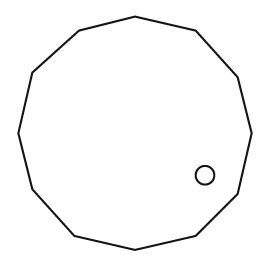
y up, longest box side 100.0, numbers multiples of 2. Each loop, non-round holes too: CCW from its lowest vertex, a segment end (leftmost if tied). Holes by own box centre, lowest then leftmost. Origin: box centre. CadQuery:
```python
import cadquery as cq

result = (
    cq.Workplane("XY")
    .moveTo(0.0, -50.0)
    .lineTo(26.0, -44.0)
    .lineTo(44.0, -26.0)
    .lineTo(50.0, 0.0)
    .lineTo(44.0, 24.0)
    .lineTo(26.0, 44.0)
    .lineTo(0.0, 50.0)
    .lineTo(-24.0, 44.0)
    .lineTo(-44.0, 26.0)
    .lineTo(-50.0, 0.0)
    .lineTo(-44.0, -24.0)
    .lineTo(-26.0, -44.0)
    .close()
    .moveTo(30.0, -18.0)
    .circle(4.0)
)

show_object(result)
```